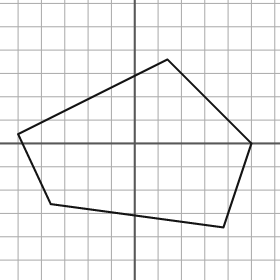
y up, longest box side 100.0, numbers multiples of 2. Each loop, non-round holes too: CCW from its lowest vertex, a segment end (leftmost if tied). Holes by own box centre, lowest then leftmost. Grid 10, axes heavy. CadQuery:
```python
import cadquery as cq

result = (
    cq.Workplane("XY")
    .moveTo(38.0, -36.0)
    .lineTo(50.0, 0.0)
    .lineTo(14.0, 36.0)
    .lineTo(-50.0, 4.0)
    .lineTo(-36.0, -26.0)
    .close()
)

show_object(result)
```